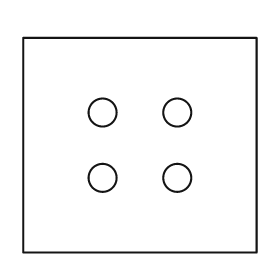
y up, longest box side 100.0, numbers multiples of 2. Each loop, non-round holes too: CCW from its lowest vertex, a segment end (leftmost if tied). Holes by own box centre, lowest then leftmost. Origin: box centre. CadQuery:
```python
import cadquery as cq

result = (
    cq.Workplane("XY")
    .moveTo(-50.0, -46.0)
    .lineTo(50.0, -46.0)
    .lineTo(50.0, 46.0)
    .lineTo(-50.0, 46.0)
    .close()
    .moveTo(-16.0, -14.0)
    .circle(6.0)
    .moveTo(16.0, -14.0)
    .circle(6.0)
    .moveTo(-16.0, 14.0)
    .circle(6.0)
    .moveTo(16.0, 14.0)
    .circle(6.0)
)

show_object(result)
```